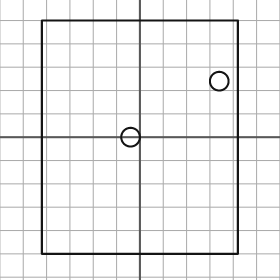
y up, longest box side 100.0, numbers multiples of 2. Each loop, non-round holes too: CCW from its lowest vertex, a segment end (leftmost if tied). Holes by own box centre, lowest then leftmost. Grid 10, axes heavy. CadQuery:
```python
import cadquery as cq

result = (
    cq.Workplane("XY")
    .moveTo(-42.0, -50.0)
    .lineTo(42.0, -50.0)
    .lineTo(42.0, 50.0)
    .lineTo(-42.0, 50.0)
    .close()
    .moveTo(-4.0, 0.0)
    .circle(4.0)
    .moveTo(34.0, 24.0)
    .circle(4.0)
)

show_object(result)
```